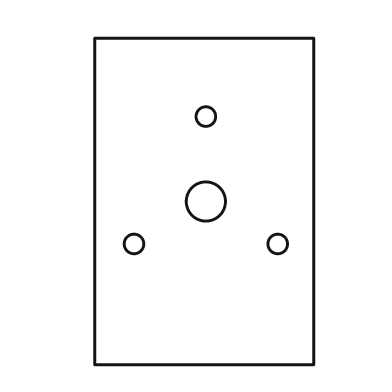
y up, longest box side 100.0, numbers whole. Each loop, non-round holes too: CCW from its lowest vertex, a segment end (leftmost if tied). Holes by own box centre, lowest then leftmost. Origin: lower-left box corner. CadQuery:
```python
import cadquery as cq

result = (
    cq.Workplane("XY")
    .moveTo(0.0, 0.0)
    .lineTo(67.0, 0.0)
    .lineTo(67.0, 100.0)
    .lineTo(0.0, 100.0)
    .close()
    .moveTo(12.0, 37.0)
    .circle(3.0)
    .moveTo(56.0, 37.0)
    .circle(3.0)
    .moveTo(34.0, 50.0)
    .circle(6.0)
    .moveTo(34.0, 76.0)
    .circle(3.0)
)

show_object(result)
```